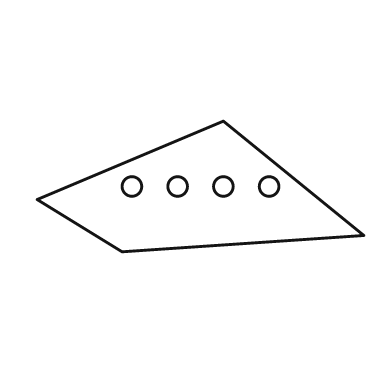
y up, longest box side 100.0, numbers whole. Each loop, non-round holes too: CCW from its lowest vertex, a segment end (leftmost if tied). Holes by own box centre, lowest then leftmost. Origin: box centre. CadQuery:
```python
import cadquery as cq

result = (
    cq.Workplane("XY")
    .moveTo(-24.0, -20.0)
    .lineTo(50.0, -15.0)
    .lineTo(7.0, 20.0)
    .lineTo(-50.0, -4.0)
    .close()
    .moveTo(-21.0, 0.0)
    .circle(3.0)
    .moveTo(-7.0, 0.0)
    .circle(3.0)
    .moveTo(7.0, 0.0)
    .circle(3.0)
    .moveTo(21.0, 0.0)
    .circle(3.0)
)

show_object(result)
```